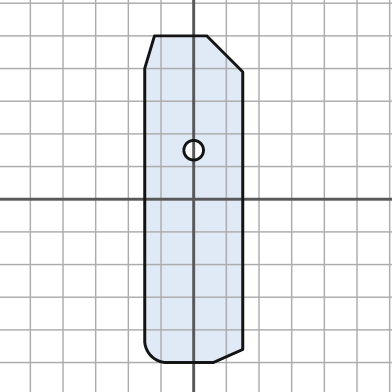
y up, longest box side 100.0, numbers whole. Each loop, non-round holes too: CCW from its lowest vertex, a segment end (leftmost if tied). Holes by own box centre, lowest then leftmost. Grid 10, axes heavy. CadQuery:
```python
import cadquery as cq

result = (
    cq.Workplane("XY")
    .moveTo(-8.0, -50.0)
    .lineTo(6.0, -50.0)
    .lineTo(15.0, -46.0)
    .lineTo(15.0, 39.0)
    .lineTo(4.0, 50.0)
    .lineTo(-12.0, 50.0)
    .lineTo(-15.0, 40.0)
    .lineTo(-15.0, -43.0)
    .threePointArc((-13.0, -48.0), (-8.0, -50.0))
    .close()
    .moveTo(0.0, 15.0)
    .circle(3.0)
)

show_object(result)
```